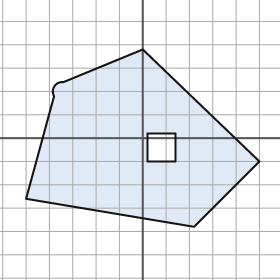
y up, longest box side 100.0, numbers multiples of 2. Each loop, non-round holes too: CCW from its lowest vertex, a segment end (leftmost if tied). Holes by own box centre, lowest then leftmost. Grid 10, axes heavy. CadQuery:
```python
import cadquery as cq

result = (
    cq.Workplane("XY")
    .moveTo(22.0, -38.0)
    .lineTo(50.0, -10.0)
    .lineTo(0.0, 38.0)
    .lineTo(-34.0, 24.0)
    .threePointArc((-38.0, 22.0), (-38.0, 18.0))
    .lineTo(-50.0, -26.0)
    .close()
    .moveTo(2.0, -10.0)
    .lineTo(14.0, -10.0)
    .lineTo(14.0, 2.0)
    .lineTo(2.0, 2.0)
    .close()
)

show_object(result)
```